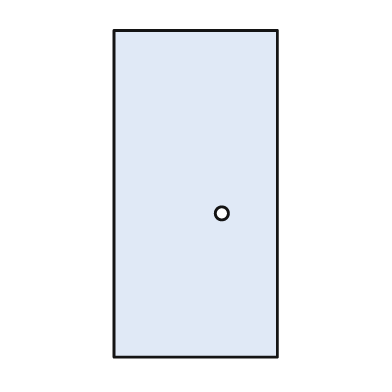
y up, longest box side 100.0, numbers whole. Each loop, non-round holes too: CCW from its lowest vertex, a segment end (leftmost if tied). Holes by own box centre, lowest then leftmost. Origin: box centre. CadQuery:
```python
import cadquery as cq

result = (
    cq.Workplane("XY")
    .moveTo(-25.0, -50.0)
    .lineTo(25.0, -50.0)
    .lineTo(25.0, 50.0)
    .lineTo(-25.0, 50.0)
    .close()
    .moveTo(8.0, -6.0)
    .circle(2.0)
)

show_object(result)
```